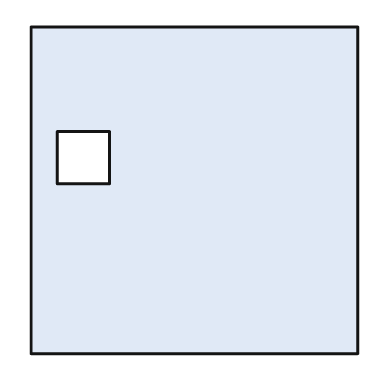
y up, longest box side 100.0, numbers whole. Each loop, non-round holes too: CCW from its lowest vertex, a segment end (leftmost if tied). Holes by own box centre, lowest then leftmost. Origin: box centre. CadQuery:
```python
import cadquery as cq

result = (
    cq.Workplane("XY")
    .moveTo(-50.0, -50.0)
    .lineTo(50.0, -50.0)
    .lineTo(50.0, 50.0)
    .lineTo(-50.0, 50.0)
    .close()
    .moveTo(-42.0, 2.0)
    .lineTo(-26.0, 2.0)
    .lineTo(-26.0, 18.0)
    .lineTo(-42.0, 18.0)
    .close()
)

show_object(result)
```